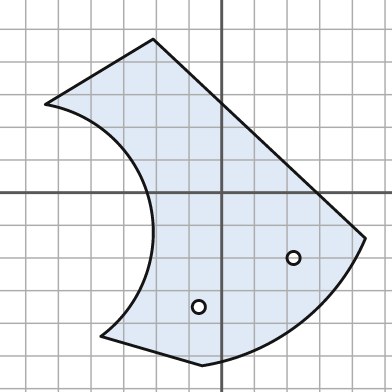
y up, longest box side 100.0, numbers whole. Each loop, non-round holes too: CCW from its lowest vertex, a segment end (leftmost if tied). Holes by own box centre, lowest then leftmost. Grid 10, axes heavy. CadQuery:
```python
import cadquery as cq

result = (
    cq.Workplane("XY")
    .moveTo(-6.0, -53.0)
    .threePointArc((24.0, -40.0), (44.0, -14.0))
    .lineTo(-21.0, 47.0)
    .lineTo(-54.0, 27.0)
    .threePointArc((-22.0, -3.0), (-37.0, -44.0))
    .close()
    .moveTo(-7.0, -35.0)
    .circle(2.0)
    .moveTo(22.0, -20.0)
    .circle(2.0)
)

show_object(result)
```